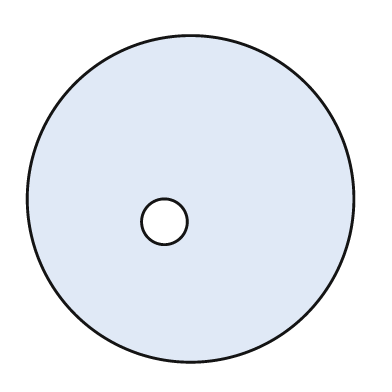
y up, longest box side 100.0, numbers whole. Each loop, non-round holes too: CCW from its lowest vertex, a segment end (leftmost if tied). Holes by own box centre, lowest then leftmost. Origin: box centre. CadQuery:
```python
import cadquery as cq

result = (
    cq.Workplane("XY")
    .moveTo(0.0, 0.0)
    .circle(50.0)
    .moveTo(-8.0, -7.0)
    .circle(7.0)
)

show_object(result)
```